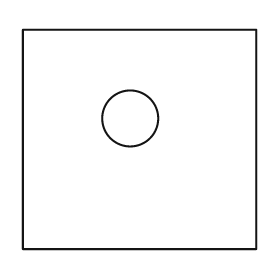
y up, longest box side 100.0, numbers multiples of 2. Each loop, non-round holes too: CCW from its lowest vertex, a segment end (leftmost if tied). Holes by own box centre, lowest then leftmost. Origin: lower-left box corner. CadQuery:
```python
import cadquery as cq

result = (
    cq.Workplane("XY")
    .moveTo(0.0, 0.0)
    .lineTo(100.0, 0.0)
    .lineTo(100.0, 94.0)
    .lineTo(0.0, 94.0)
    .close()
    .moveTo(46.0, 56.0)
    .circle(12.0)
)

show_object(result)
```